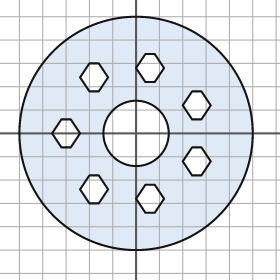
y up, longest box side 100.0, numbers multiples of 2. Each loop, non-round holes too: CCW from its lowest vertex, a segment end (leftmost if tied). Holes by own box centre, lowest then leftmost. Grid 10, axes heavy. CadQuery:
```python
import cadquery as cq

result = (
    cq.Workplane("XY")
    .moveTo(0.0, 0.0)
    .circle(50.0)
    .moveTo(4.0, -34.0)
    .lineTo(8.0, -34.0)
    .lineTo(12.0, -28.0)
    .lineTo(8.0, -22.0)
    .lineTo(4.0, -22.0)
    .lineTo(0.0, -28.0)
    .close()
    .moveTo(-20.0, -30.0)
    .lineTo(-16.0, -30.0)
    .lineTo(-12.0, -24.0)
    .lineTo(-16.0, -18.0)
    .lineTo(-20.0, -18.0)
    .lineTo(-24.0, -24.0)
    .close()
    .moveTo(24.0, -18.0)
    .lineTo(28.0, -18.0)
    .lineTo(32.0, -12.0)
    .lineTo(28.0, -6.0)
    .lineTo(24.0, -6.0)
    .lineTo(20.0, -12.0)
    .close()
    .moveTo(-32.0, -6.0)
    .lineTo(-28.0, -6.0)
    .lineTo(-24.0, 0.0)
    .lineTo(-28.0, 6.0)
    .lineTo(-32.0, 6.0)
    .lineTo(-36.0, 0.0)
    .close()
    .moveTo(0.0, 0.0)
    .circle(14.0)
    .moveTo(24.0, 6.0)
    .lineTo(28.0, 6.0)
    .lineTo(32.0, 12.0)
    .lineTo(28.0, 18.0)
    .lineTo(24.0, 18.0)
    .lineTo(20.0, 12.0)
    .close()
    .moveTo(-20.0, 18.0)
    .lineTo(-16.0, 18.0)
    .lineTo(-12.0, 24.0)
    .lineTo(-16.0, 30.0)
    .lineTo(-20.0, 30.0)
    .lineTo(-24.0, 24.0)
    .close()
    .moveTo(4.0, 22.0)
    .lineTo(8.0, 22.0)
    .lineTo(12.0, 28.0)
    .lineTo(8.0, 34.0)
    .lineTo(4.0, 34.0)
    .lineTo(0.0, 28.0)
    .close()
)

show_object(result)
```